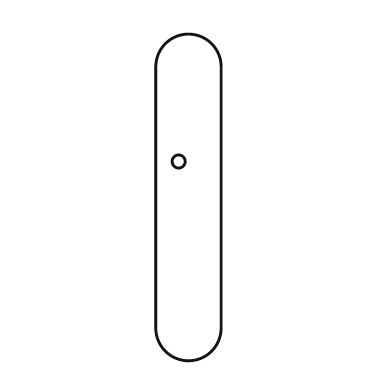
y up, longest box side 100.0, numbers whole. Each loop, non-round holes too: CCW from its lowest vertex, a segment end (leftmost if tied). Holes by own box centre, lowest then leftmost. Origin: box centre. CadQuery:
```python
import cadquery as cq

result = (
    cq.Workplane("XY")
    .moveTo(-10.0, -40.0)
    .threePointArc((0.0, -50.0), (10.0, -40.0))
    .lineTo(10.0, 40.0)
    .threePointArc((0.0, 50.0), (-10.0, 40.0))
    .close()
    .moveTo(-3.0, 11.0)
    .circle(2.0)
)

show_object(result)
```